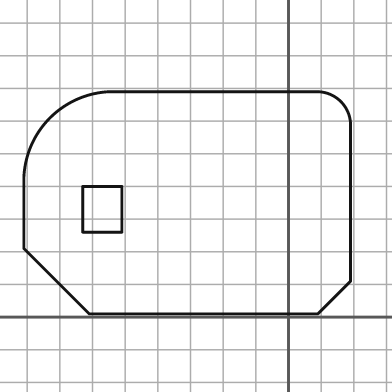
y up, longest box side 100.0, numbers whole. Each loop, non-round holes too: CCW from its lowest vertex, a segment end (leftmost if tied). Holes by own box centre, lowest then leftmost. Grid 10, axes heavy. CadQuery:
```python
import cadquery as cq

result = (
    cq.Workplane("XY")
    .moveTo(-61.0, 1.0)
    .lineTo(9.0, 1.0)
    .lineTo(19.0, 11.0)
    .lineTo(19.0, 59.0)
    .threePointArc((16.0, 66.0), (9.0, 69.0))
    .lineTo(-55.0, 69.0)
    .threePointArc((-73.0, 61.0), (-81.0, 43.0))
    .lineTo(-81.0, 21.0)
    .close()
    .moveTo(-63.0, 26.0)
    .lineTo(-51.0, 26.0)
    .lineTo(-51.0, 40.0)
    .lineTo(-63.0, 40.0)
    .close()
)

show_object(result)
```